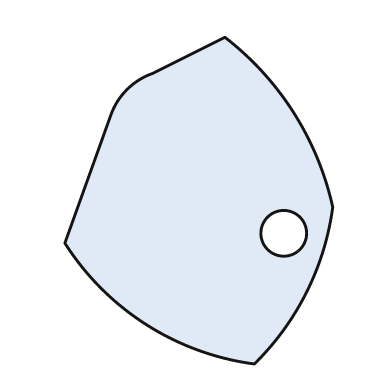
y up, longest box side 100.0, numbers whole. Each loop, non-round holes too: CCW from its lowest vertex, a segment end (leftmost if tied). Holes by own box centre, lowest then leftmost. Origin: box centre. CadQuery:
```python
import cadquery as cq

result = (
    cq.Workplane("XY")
    .moveTo(17.0, -50.0)
    .threePointArc((33.0, -28.0), (41.0, -2.0))
    .threePointArc((29.0, 27.0), (8.0, 50.0))
    .lineTo(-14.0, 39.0)
    .threePointArc((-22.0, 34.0), (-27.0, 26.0))
    .lineTo(-41.0, -13.0)
    .threePointArc((-16.0, -38.0), (17.0, -50.0))
    .close()
    .moveTo(26.0, -10.0)
    .circle(7.0)
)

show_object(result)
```